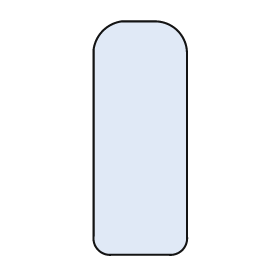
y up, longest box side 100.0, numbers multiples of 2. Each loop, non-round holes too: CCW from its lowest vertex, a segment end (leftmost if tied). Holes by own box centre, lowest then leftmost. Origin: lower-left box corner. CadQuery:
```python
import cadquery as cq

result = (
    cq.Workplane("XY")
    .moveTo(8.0, 0.0)
    .lineTo(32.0, 0.0)
    .threePointArc((38.0, 2.0), (40.0, 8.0))
    .lineTo(40.0, 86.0)
    .threePointArc((36.0, 96.0), (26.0, 100.0))
    .lineTo(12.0, 100.0)
    .threePointArc((4.0, 96.0), (0.0, 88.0))
    .lineTo(0.0, 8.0)
    .threePointArc((2.0, 2.0), (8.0, 0.0))
    .close()
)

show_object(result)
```